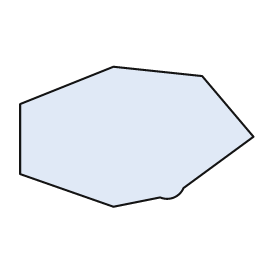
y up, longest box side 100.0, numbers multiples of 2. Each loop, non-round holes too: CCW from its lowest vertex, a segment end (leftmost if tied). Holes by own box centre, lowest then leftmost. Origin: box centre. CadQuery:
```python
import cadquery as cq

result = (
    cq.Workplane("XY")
    .moveTo(-10.0, -30.0)
    .lineTo(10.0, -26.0)
    .threePointArc((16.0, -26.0), (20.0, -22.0))
    .lineTo(50.0, 0.0)
    .lineTo(28.0, 26.0)
    .lineTo(-10.0, 30.0)
    .lineTo(-50.0, 14.0)
    .lineTo(-50.0, -16.0)
    .close()
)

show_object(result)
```